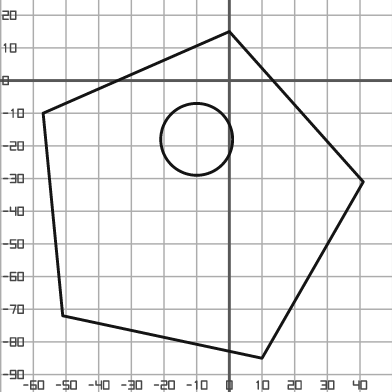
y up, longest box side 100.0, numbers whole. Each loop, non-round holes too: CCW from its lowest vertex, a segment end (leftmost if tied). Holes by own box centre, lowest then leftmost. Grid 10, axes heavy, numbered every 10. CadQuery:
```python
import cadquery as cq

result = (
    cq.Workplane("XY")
    .moveTo(10.0, -85.0)
    .lineTo(41.0, -31.0)
    .lineTo(0.0, 15.0)
    .lineTo(-57.0, -10.0)
    .lineTo(-51.0, -72.0)
    .close()
    .moveTo(-10.0, -18.0)
    .circle(11.0)
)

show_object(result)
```